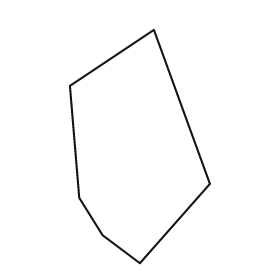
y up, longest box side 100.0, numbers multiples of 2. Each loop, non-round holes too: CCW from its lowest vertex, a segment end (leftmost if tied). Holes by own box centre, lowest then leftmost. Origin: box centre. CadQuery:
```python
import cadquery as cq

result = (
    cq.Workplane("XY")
    .moveTo(0.0, -50.0)
    .lineTo(30.0, -16.0)
    .lineTo(6.0, 50.0)
    .lineTo(-30.0, 26.0)
    .lineTo(-26.0, -22.0)
    .lineTo(-16.0, -38.0)
    .close()
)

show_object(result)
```